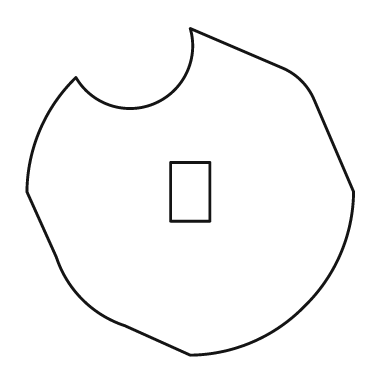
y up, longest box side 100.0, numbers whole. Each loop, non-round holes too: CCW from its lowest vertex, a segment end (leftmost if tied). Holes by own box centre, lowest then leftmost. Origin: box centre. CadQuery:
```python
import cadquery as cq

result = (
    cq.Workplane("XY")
    .moveTo(0.0, -50.0)
    .threePointArc((19.0, -46.0), (35.0, -35.0))
    .threePointArc((46.0, -19.0), (50.0, 0.0))
    .lineTo(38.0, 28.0)
    .threePointArc((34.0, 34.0), (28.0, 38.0))
    .lineTo(0.0, 50.0)
    .threePointArc((-11.0, 27.0), (-35.0, 35.0))
    .threePointArc((-46.0, 19.0), (-50.0, 0.0))
    .lineTo(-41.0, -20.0)
    .threePointArc((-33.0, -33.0), (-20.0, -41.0))
    .close()
    .moveTo(-6.0, -9.0)
    .lineTo(6.0, -9.0)
    .lineTo(6.0, 9.0)
    .lineTo(-6.0, 9.0)
    .close()
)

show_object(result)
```